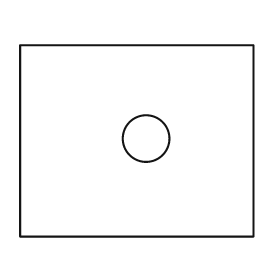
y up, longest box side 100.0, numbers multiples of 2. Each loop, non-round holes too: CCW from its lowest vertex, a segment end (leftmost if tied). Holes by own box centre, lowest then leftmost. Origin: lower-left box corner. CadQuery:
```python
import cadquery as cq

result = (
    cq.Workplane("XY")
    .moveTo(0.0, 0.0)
    .lineTo(100.0, 0.0)
    .lineTo(100.0, 82.0)
    .lineTo(0.0, 82.0)
    .close()
    .moveTo(54.0, 42.0)
    .circle(10.0)
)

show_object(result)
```